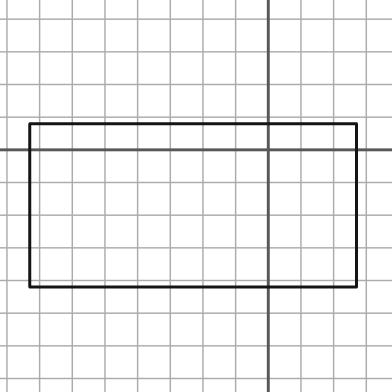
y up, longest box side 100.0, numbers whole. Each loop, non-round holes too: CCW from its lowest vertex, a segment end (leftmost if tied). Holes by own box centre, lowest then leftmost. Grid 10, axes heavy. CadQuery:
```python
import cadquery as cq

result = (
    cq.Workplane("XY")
    .moveTo(-73.0, -42.0)
    .lineTo(27.0, -42.0)
    .lineTo(27.0, 8.0)
    .lineTo(-73.0, 8.0)
    .close()
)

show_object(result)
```